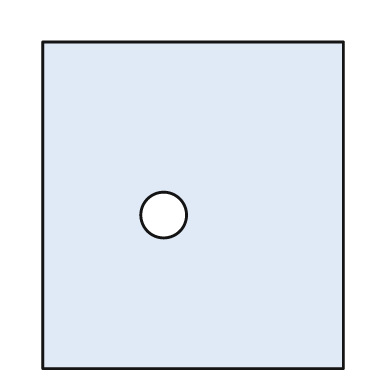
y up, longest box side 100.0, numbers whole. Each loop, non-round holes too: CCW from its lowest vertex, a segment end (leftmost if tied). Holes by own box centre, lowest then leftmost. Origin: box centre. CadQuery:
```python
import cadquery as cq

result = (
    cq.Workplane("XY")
    .moveTo(-46.0, -50.0)
    .lineTo(46.0, -50.0)
    .lineTo(46.0, 50.0)
    .lineTo(-46.0, 50.0)
    .close()
    .moveTo(-9.0, -3.0)
    .circle(7.0)
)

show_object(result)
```